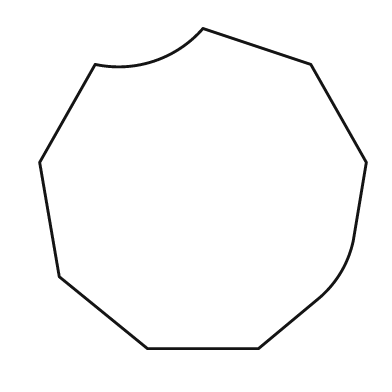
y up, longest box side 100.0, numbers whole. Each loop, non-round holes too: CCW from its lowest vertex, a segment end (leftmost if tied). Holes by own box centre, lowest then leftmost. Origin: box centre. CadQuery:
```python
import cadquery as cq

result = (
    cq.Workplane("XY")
    .moveTo(-17.0, -49.0)
    .lineTo(17.0, -49.0)
    .lineTo(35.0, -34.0)
    .threePointArc((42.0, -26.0), (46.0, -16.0))
    .lineTo(50.0, 8.0)
    .lineTo(33.0, 38.0)
    .lineTo(0.0, 49.0)
    .threePointArc((-15.0, 39.0), (-33.0, 38.0))
    .lineTo(-50.0, 8.0)
    .lineTo(-44.0, -27.0)
    .close()
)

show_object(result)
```